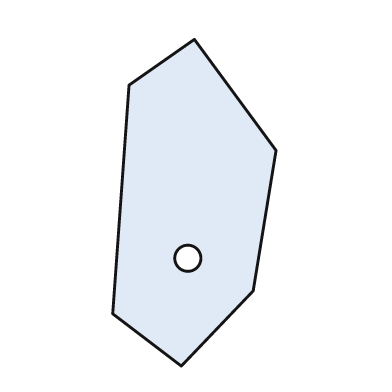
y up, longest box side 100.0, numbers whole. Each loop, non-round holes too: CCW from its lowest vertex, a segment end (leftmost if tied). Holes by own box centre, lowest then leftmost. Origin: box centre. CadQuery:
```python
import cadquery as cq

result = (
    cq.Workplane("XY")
    .moveTo(-4.0, -50.0)
    .lineTo(18.0, -27.0)
    .lineTo(25.0, 16.0)
    .lineTo(0.0, 50.0)
    .lineTo(-20.0, 36.0)
    .lineTo(-25.0, -34.0)
    .close()
    .moveTo(-2.0, -17.0)
    .circle(4.0)
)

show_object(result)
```